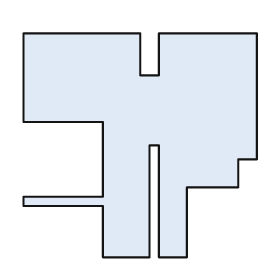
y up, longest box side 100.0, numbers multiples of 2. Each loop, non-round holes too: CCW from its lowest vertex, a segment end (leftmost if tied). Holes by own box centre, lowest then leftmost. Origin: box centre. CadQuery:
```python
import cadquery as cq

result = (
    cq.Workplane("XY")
    .moveTo(-16.0, -48.0)
    .lineTo(4.0, -48.0)
    .lineTo(4.0, 0.0)
    .lineTo(8.0, 0.0)
    .lineTo(8.0, -48.0)
    .lineTo(20.0, -48.0)
    .lineTo(20.0, -18.0)
    .lineTo(42.0, -18.0)
    .lineTo(42.0, -6.0)
    .lineTo(50.0, -6.0)
    .lineTo(50.0, 48.0)
    .lineTo(8.0, 48.0)
    .lineTo(8.0, 30.0)
    .lineTo(0.0, 30.0)
    .lineTo(0.0, 48.0)
    .lineTo(-50.0, 48.0)
    .lineTo(-50.0, 10.0)
    .lineTo(-16.0, 10.0)
    .lineTo(-16.0, -22.0)
    .lineTo(-50.0, -22.0)
    .lineTo(-50.0, -26.0)
    .lineTo(-16.0, -26.0)
    .close()
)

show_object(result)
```